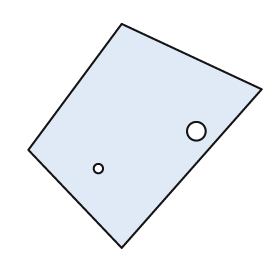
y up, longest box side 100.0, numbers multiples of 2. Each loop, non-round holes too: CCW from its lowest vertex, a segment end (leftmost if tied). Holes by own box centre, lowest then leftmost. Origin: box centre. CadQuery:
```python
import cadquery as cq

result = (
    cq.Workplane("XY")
    .moveTo(-10.0, -48.0)
    .lineTo(50.0, 20.0)
    .lineTo(-10.0, 48.0)
    .lineTo(-50.0, -6.0)
    .close()
    .moveTo(-20.0, -14.0)
    .circle(2.0)
    .moveTo(22.0, 2.0)
    .circle(4.0)
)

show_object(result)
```